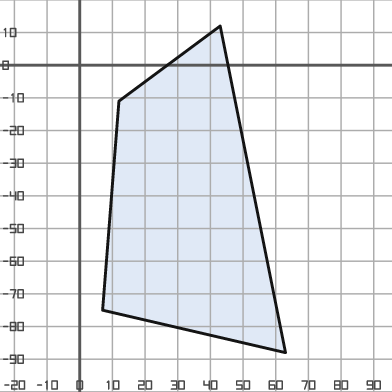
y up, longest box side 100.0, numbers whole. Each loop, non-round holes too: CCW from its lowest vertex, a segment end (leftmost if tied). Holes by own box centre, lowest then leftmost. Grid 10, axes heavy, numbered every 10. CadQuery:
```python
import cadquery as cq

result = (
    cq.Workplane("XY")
    .moveTo(63.0, -88.0)
    .lineTo(43.0, 12.0)
    .lineTo(12.0, -11.0)
    .lineTo(7.0, -75.0)
    .close()
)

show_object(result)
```